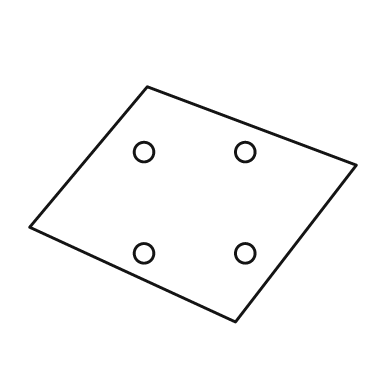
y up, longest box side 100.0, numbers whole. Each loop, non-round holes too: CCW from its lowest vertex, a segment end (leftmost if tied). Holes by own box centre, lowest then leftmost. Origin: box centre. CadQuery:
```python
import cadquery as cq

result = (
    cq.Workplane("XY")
    .moveTo(13.0, -36.0)
    .lineTo(50.0, 12.0)
    .lineTo(-14.0, 36.0)
    .lineTo(-50.0, -7.0)
    .close()
    .moveTo(-15.0, -15.0)
    .circle(3.0)
    .moveTo(16.0, -15.0)
    .circle(3.0)
    .moveTo(-15.0, 16.0)
    .circle(3.0)
    .moveTo(16.0, 16.0)
    .circle(3.0)
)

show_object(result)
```